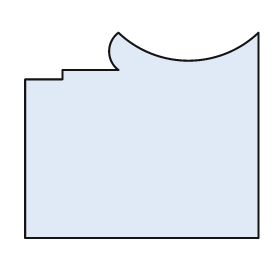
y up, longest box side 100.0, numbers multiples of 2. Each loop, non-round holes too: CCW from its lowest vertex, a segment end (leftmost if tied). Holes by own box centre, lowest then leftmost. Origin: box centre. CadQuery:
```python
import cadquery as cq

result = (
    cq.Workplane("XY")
    .moveTo(-50.0, -44.0)
    .lineTo(50.0, -44.0)
    .lineTo(50.0, 44.0)
    .threePointArc((20.0, 32.0), (-10.0, 44.0))
    .threePointArc((-14.0, 36.0), (-10.0, 28.0))
    .lineTo(-34.0, 28.0)
    .lineTo(-34.0, 24.0)
    .lineTo(-50.0, 24.0)
    .close()
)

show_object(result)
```